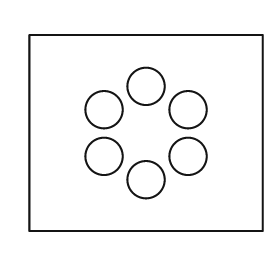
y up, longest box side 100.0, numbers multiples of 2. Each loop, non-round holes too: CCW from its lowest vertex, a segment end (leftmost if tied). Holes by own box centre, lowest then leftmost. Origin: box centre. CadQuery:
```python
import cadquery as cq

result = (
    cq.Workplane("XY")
    .moveTo(-50.0, -42.0)
    .lineTo(50.0, -42.0)
    .lineTo(50.0, 42.0)
    .lineTo(-50.0, 42.0)
    .close()
    .moveTo(0.0, -20.0)
    .circle(8.0)
    .moveTo(-18.0, -10.0)
    .circle(8.0)
    .moveTo(18.0, -10.0)
    .circle(8.0)
    .moveTo(-18.0, 10.0)
    .circle(8.0)
    .moveTo(18.0, 10.0)
    .circle(8.0)
    .moveTo(0.0, 20.0)
    .circle(8.0)
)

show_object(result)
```